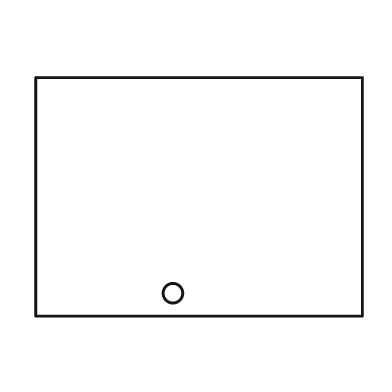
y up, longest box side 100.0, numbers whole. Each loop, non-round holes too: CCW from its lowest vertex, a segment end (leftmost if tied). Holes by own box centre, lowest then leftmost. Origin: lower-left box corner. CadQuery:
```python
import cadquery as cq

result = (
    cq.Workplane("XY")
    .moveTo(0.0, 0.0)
    .lineTo(100.0, 0.0)
    .lineTo(100.0, 73.0)
    .lineTo(0.0, 73.0)
    .close()
    .moveTo(42.0, 7.0)
    .circle(3.0)
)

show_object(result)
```